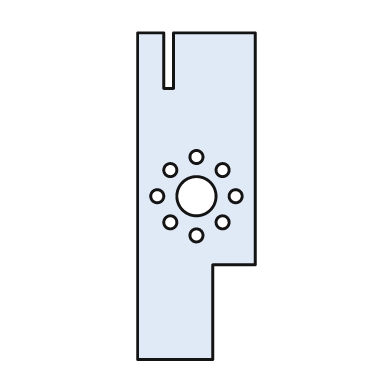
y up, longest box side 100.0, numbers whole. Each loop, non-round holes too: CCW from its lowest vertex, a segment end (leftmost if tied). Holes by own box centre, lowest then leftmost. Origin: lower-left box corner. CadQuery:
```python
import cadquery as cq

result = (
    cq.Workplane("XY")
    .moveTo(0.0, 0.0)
    .lineTo(23.0, 0.0)
    .lineTo(23.0, 29.0)
    .lineTo(36.0, 29.0)
    .lineTo(36.0, 100.0)
    .lineTo(11.0, 100.0)
    .lineTo(11.0, 83.0)
    .lineTo(8.0, 83.0)
    .lineTo(8.0, 100.0)
    .lineTo(0.0, 100.0)
    .close()
    .moveTo(18.0, 38.0)
    .circle(2.0)
    .moveTo(10.0, 42.0)
    .circle(2.0)
    .moveTo(26.0, 42.0)
    .circle(2.0)
    .moveTo(6.0, 50.0)
    .circle(2.0)
    .moveTo(18.0, 50.0)
    .circle(6.0)
    .moveTo(30.0, 50.0)
    .circle(2.0)
    .moveTo(10.0, 58.0)
    .circle(2.0)
    .moveTo(26.0, 58.0)
    .circle(2.0)
    .moveTo(18.0, 62.0)
    .circle(2.0)
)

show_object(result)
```